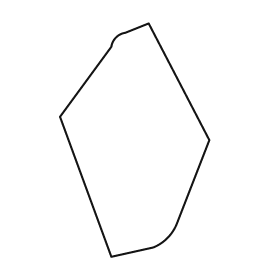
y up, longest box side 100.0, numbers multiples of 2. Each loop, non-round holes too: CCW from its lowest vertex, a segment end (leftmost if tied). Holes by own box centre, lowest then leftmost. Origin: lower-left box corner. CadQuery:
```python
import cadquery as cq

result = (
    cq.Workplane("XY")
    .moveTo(22.0, 0.0)
    .lineTo(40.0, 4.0)
    .threePointArc((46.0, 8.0), (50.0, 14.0))
    .lineTo(64.0, 50.0)
    .lineTo(38.0, 100.0)
    .lineTo(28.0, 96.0)
    .threePointArc((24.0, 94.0), (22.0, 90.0))
    .lineTo(0.0, 60.0)
    .close()
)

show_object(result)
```